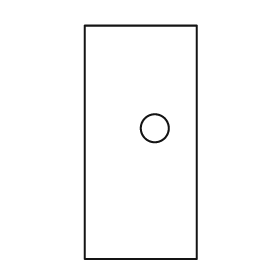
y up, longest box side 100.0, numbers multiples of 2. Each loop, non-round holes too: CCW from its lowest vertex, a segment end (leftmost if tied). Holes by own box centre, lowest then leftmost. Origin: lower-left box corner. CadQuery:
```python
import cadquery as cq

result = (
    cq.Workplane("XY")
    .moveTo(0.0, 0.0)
    .lineTo(48.0, 0.0)
    .lineTo(48.0, 100.0)
    .lineTo(0.0, 100.0)
    .close()
    .moveTo(30.0, 56.0)
    .circle(6.0)
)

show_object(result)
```